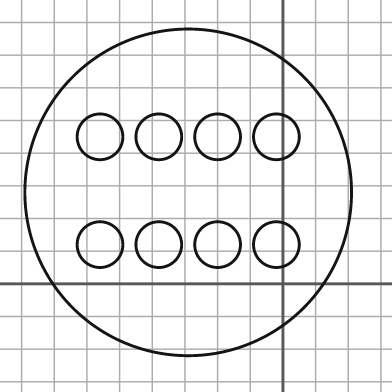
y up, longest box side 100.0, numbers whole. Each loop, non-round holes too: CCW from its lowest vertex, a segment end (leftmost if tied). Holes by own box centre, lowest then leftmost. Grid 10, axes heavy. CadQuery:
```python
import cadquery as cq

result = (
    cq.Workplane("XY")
    .moveTo(-29.0, 28.0)
    .circle(50.0)
    .moveTo(-56.0, 12.0)
    .circle(7.0)
    .moveTo(-38.0, 12.0)
    .circle(7.0)
    .moveTo(-20.0, 12.0)
    .circle(7.0)
    .moveTo(-2.0, 12.0)
    .circle(7.0)
    .moveTo(-56.0, 45.0)
    .circle(7.0)
    .moveTo(-38.0, 45.0)
    .circle(7.0)
    .moveTo(-20.0, 45.0)
    .circle(7.0)
    .moveTo(-2.0, 45.0)
    .circle(7.0)
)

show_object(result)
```